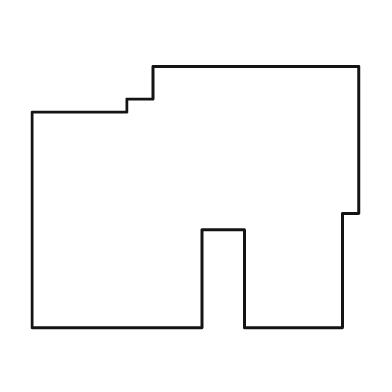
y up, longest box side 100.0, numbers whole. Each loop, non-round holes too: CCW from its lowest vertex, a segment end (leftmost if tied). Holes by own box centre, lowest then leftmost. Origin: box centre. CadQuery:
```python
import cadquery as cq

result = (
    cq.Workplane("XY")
    .moveTo(-50.0, -40.0)
    .lineTo(2.0, -40.0)
    .lineTo(2.0, -10.0)
    .lineTo(15.0, -10.0)
    .lineTo(15.0, -40.0)
    .lineTo(45.0, -40.0)
    .lineTo(45.0, -5.0)
    .lineTo(50.0, -5.0)
    .lineTo(50.0, 40.0)
    .lineTo(-13.0, 40.0)
    .lineTo(-13.0, 30.0)
    .lineTo(-21.0, 30.0)
    .lineTo(-21.0, 26.0)
    .lineTo(-50.0, 26.0)
    .close()
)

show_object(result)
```